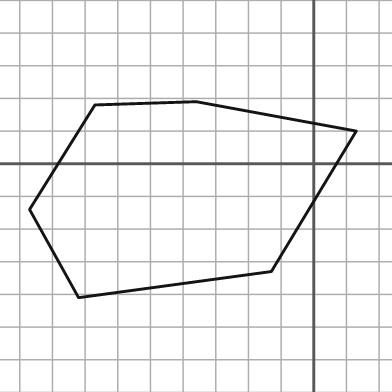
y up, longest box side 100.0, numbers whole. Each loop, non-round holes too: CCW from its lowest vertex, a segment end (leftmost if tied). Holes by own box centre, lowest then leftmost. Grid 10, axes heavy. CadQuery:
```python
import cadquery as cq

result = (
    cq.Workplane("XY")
    .moveTo(-72.0, -41.0)
    .lineTo(-13.0, -33.0)
    .lineTo(13.0, 10.0)
    .lineTo(-36.0, 19.0)
    .lineTo(-67.0, 18.0)
    .lineTo(-87.0, -14.0)
    .close()
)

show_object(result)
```